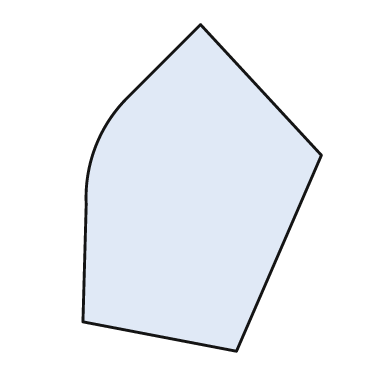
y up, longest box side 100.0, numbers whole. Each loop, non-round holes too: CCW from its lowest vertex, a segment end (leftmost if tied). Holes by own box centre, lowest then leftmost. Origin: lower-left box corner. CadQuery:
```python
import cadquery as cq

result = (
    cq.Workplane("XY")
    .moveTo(47.0, 0.0)
    .lineTo(73.0, 60.0)
    .lineTo(36.0, 100.0)
    .lineTo(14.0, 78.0)
    .threePointArc((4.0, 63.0), (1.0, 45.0))
    .lineTo(0.0, 9.0)
    .close()
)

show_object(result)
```